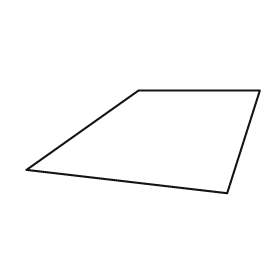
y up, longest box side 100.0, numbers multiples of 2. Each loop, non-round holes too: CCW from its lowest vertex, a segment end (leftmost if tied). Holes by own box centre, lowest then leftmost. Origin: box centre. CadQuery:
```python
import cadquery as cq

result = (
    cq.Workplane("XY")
    .moveTo(36.0, -22.0)
    .lineTo(50.0, 22.0)
    .lineTo(-2.0, 22.0)
    .lineTo(-50.0, -12.0)
    .close()
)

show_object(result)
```